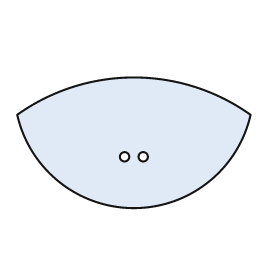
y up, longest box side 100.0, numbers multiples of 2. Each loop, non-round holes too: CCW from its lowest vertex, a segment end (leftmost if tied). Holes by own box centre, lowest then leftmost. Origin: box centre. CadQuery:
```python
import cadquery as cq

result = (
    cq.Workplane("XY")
    .moveTo(-50.0, 12.0)
    .threePointArc((0.0, -28.0), (50.0, 12.0))
    .threePointArc((0.0, 28.0), (-50.0, 12.0))
    .close()
    .moveTo(-4.0, -6.0)
    .circle(2.0)
    .moveTo(4.0, -6.0)
    .circle(2.0)
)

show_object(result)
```